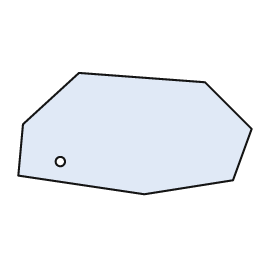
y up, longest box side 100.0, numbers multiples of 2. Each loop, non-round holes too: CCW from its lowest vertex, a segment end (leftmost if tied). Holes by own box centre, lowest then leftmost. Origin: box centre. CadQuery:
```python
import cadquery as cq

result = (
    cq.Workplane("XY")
    .moveTo(4.0, -26.0)
    .lineTo(42.0, -20.0)
    .lineTo(50.0, 2.0)
    .lineTo(30.0, 22.0)
    .lineTo(-24.0, 26.0)
    .lineTo(-48.0, 4.0)
    .lineTo(-50.0, -18.0)
    .close()
    .moveTo(-32.0, -12.0)
    .circle(2.0)
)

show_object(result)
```